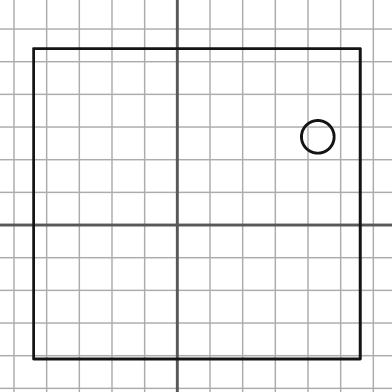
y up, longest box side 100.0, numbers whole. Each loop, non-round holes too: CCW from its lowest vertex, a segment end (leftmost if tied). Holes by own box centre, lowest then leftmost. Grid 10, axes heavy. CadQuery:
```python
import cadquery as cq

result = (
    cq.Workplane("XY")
    .moveTo(-44.0, -41.0)
    .lineTo(56.0, -41.0)
    .lineTo(56.0, 54.0)
    .lineTo(-44.0, 54.0)
    .close()
    .moveTo(43.0, 27.0)
    .circle(5.0)
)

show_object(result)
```